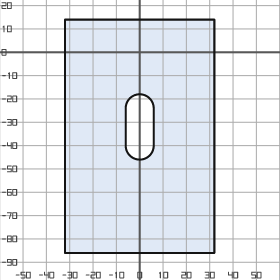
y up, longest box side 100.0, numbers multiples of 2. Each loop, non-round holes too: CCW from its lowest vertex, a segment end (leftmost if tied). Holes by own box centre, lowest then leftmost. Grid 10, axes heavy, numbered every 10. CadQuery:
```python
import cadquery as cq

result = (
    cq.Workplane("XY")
    .moveTo(-32.0, -86.0)
    .lineTo(32.0, -86.0)
    .lineTo(32.0, 14.0)
    .lineTo(-32.0, 14.0)
    .close()
    .moveTo(-6.0, -40.0)
    .threePointArc((0.0, -46.0), (6.0, -40.0))
    .lineTo(6.0, -24.0)
    .threePointArc((0.0, -18.0), (-6.0, -24.0))
    .close()
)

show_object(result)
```